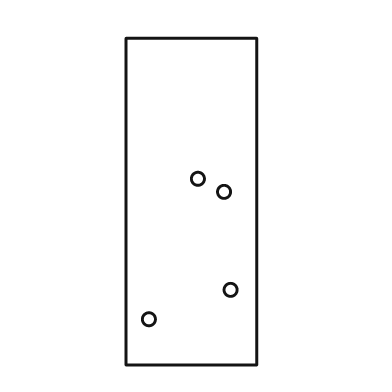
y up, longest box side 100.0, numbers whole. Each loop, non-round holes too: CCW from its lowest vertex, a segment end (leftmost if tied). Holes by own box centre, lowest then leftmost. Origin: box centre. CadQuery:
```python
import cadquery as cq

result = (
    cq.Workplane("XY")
    .moveTo(-20.0, -50.0)
    .lineTo(20.0, -50.0)
    .lineTo(20.0, 50.0)
    .lineTo(-20.0, 50.0)
    .close()
    .moveTo(-13.0, -36.0)
    .circle(2.0)
    .moveTo(12.0, -27.0)
    .circle(2.0)
    .moveTo(10.0, 3.0)
    .circle(2.0)
    .moveTo(2.0, 7.0)
    .circle(2.0)
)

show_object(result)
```